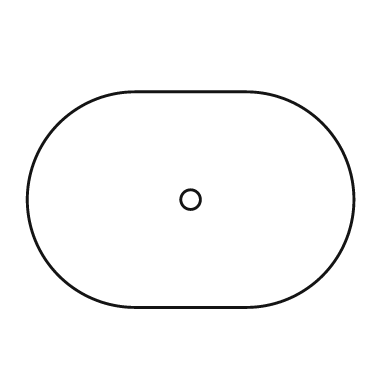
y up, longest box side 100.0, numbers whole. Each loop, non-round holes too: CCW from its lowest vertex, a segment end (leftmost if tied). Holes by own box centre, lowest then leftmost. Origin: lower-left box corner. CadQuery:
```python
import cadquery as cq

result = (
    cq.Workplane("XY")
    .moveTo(33.0, 0.0)
    .lineTo(67.0, 0.0)
    .threePointArc((100.0, 33.0), (67.0, 66.0))
    .lineTo(33.0, 66.0)
    .threePointArc((0.0, 33.0), (33.0, 0.0))
    .close()
    .moveTo(50.0, 33.0)
    .circle(3.0)
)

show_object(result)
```